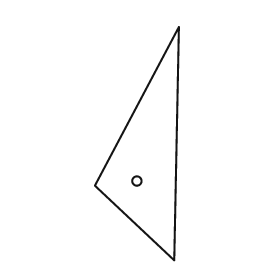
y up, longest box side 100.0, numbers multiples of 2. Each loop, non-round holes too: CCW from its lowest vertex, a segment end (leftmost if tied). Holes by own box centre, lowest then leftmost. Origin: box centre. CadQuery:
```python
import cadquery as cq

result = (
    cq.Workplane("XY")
    .moveTo(16.0, -50.0)
    .lineTo(18.0, 50.0)
    .lineTo(-18.0, -18.0)
    .close()
    .moveTo(0.0, -16.0)
    .circle(2.0)
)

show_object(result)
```